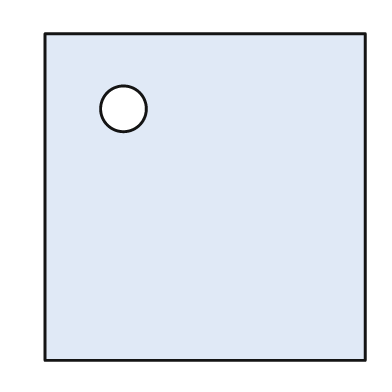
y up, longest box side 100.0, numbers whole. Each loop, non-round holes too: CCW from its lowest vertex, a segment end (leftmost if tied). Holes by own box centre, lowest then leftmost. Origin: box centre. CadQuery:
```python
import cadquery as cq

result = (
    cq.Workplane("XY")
    .moveTo(-49.0, -50.0)
    .lineTo(49.0, -50.0)
    .lineTo(49.0, 50.0)
    .lineTo(-49.0, 50.0)
    .close()
    .moveTo(-25.0, 27.0)
    .circle(7.0)
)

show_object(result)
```